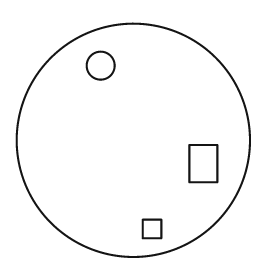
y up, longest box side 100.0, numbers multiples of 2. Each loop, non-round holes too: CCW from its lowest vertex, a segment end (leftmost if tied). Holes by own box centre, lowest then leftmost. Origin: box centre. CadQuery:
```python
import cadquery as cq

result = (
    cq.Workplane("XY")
    .moveTo(0.0, 0.0)
    .circle(50.0)
    .moveTo(4.0, -42.0)
    .lineTo(12.0, -42.0)
    .lineTo(12.0, -34.0)
    .lineTo(4.0, -34.0)
    .close()
    .moveTo(24.0, -18.0)
    .lineTo(36.0, -18.0)
    .lineTo(36.0, -2.0)
    .lineTo(24.0, -2.0)
    .close()
    .moveTo(-14.0, 32.0)
    .circle(6.0)
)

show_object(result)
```